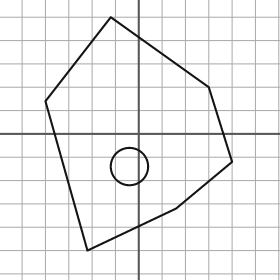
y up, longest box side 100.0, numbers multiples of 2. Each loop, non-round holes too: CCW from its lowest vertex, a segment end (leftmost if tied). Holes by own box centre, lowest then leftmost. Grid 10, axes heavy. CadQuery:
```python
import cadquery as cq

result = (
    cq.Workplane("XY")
    .moveTo(-22.0, -50.0)
    .lineTo(16.0, -32.0)
    .lineTo(40.0, -12.0)
    .lineTo(30.0, 20.0)
    .lineTo(-12.0, 50.0)
    .lineTo(-40.0, 14.0)
    .close()
    .moveTo(-4.0, -14.0)
    .circle(8.0)
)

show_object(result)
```